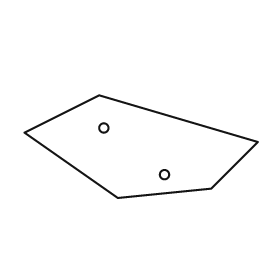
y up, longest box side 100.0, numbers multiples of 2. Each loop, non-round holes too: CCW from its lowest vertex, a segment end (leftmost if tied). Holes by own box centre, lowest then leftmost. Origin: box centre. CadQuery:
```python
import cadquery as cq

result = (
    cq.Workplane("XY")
    .moveTo(-10.0, -22.0)
    .lineTo(30.0, -18.0)
    .lineTo(50.0, 2.0)
    .lineTo(-18.0, 22.0)
    .lineTo(-50.0, 6.0)
    .close()
    .moveTo(10.0, -12.0)
    .circle(2.0)
    .moveTo(-16.0, 8.0)
    .circle(2.0)
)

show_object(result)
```